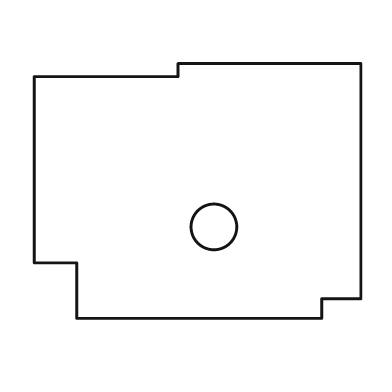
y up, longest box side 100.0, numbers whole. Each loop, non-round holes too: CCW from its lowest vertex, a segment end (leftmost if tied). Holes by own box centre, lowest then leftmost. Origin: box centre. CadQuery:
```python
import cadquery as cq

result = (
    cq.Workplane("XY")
    .moveTo(-37.0, -39.0)
    .lineTo(38.0, -39.0)
    .lineTo(38.0, -33.0)
    .lineTo(50.0, -33.0)
    .lineTo(50.0, 39.0)
    .lineTo(-6.0, 39.0)
    .lineTo(-6.0, 35.0)
    .lineTo(-50.0, 35.0)
    .lineTo(-50.0, -22.0)
    .lineTo(-37.0, -22.0)
    .close()
    .moveTo(5.0, -11.0)
    .circle(7.0)
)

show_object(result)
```